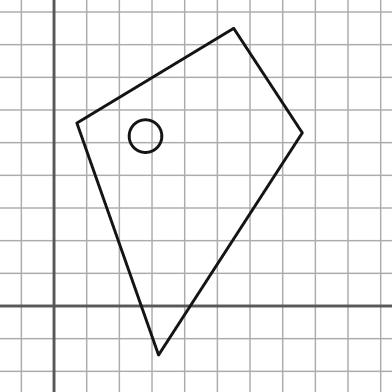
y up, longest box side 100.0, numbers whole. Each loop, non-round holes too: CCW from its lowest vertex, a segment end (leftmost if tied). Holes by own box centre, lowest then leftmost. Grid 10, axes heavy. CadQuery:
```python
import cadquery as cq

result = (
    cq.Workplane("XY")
    .moveTo(32.0, -15.0)
    .lineTo(76.0, 53.0)
    .lineTo(55.0, 85.0)
    .lineTo(7.0, 56.0)
    .close()
    .moveTo(28.0, 52.0)
    .circle(5.0)
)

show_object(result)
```